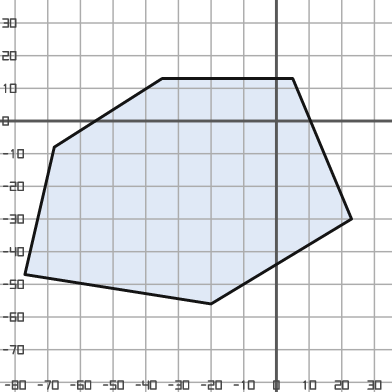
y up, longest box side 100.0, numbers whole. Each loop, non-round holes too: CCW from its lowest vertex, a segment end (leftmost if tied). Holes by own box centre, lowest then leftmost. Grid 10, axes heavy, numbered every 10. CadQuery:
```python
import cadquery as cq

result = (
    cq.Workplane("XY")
    .moveTo(-20.0, -56.0)
    .lineTo(23.0, -30.0)
    .lineTo(5.0, 13.0)
    .lineTo(-35.0, 13.0)
    .lineTo(-68.0, -8.0)
    .lineTo(-77.0, -47.0)
    .close()
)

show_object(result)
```